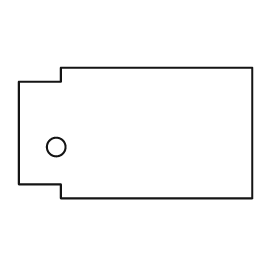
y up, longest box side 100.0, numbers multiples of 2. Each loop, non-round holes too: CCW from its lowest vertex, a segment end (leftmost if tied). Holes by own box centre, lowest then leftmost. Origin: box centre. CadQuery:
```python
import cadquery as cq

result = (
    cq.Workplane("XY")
    .moveTo(-32.0, -28.0)
    .lineTo(50.0, -28.0)
    .lineTo(50.0, 28.0)
    .lineTo(-32.0, 28.0)
    .lineTo(-32.0, 22.0)
    .lineTo(-50.0, 22.0)
    .lineTo(-50.0, -22.0)
    .lineTo(-32.0, -22.0)
    .close()
    .moveTo(-34.0, -6.0)
    .circle(4.0)
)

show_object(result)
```